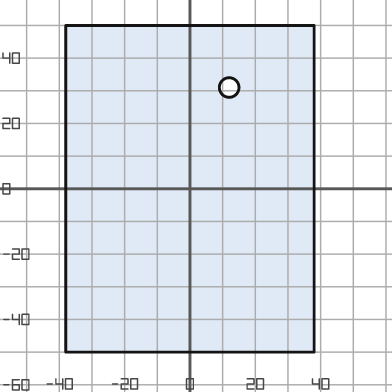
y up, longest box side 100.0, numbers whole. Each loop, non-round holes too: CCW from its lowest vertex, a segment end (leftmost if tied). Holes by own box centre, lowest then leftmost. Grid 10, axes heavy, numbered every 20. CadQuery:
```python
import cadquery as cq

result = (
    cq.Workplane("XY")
    .moveTo(-38.0, -50.0)
    .lineTo(38.0, -50.0)
    .lineTo(38.0, 50.0)
    .lineTo(-38.0, 50.0)
    .close()
    .moveTo(12.0, 31.0)
    .circle(3.0)
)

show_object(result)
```